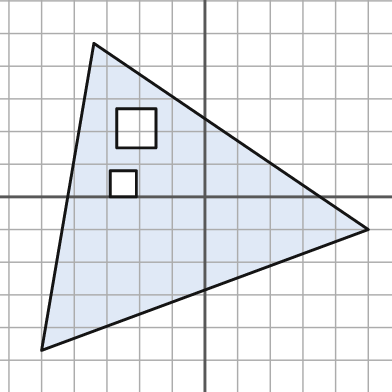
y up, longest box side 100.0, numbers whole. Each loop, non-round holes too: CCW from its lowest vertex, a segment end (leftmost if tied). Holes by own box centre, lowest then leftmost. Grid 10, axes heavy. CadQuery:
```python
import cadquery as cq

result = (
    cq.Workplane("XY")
    .moveTo(-50.0, -47.0)
    .lineTo(50.0, -10.0)
    .lineTo(-34.0, 47.0)
    .close()
    .moveTo(-29.0, 0.0)
    .lineTo(-21.0, 0.0)
    .lineTo(-21.0, 8.0)
    .lineTo(-29.0, 8.0)
    .close()
    .moveTo(-27.0, 15.0)
    .lineTo(-15.0, 15.0)
    .lineTo(-15.0, 27.0)
    .lineTo(-27.0, 27.0)
    .close()
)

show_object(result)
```